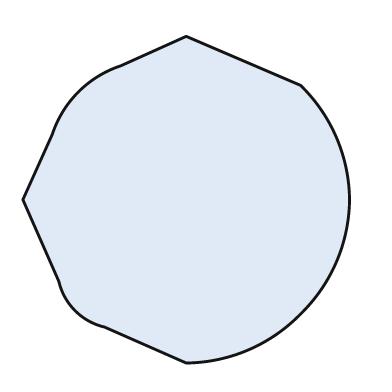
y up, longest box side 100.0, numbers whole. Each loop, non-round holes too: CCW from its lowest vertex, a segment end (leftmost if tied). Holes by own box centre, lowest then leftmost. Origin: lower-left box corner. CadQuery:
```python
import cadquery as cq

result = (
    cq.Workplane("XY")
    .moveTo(50.0, 0.0)
    .threePointArc((69.0, 4.0), (85.0, 15.0))
    .threePointArc((96.0, 31.0), (100.0, 50.0))
    .threePointArc((96.0, 69.0), (85.0, 85.0))
    .lineTo(50.0, 100.0)
    .lineTo(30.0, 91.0)
    .threePointArc((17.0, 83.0), (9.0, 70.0))
    .lineTo(0.0, 50.0)
    .lineTo(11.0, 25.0)
    .threePointArc((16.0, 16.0), (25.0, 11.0))
    .close()
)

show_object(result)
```